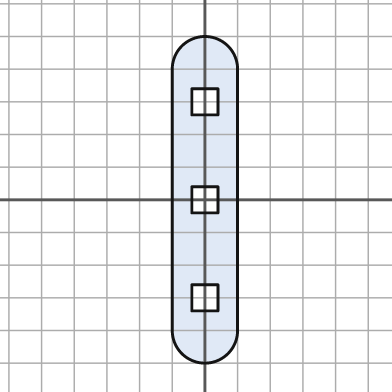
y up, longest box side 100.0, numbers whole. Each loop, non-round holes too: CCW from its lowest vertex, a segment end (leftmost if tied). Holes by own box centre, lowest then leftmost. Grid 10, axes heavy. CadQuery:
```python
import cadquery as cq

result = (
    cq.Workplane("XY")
    .moveTo(-10.0, -40.0)
    .threePointArc((0.0, -50.0), (10.0, -40.0))
    .lineTo(10.0, 40.0)
    .threePointArc((0.0, 50.0), (-10.0, 40.0))
    .close()
    .moveTo(-4.0, -34.0)
    .lineTo(4.0, -34.0)
    .lineTo(4.0, -26.0)
    .lineTo(-4.0, -26.0)
    .close()
    .moveTo(-4.0, -4.0)
    .lineTo(4.0, -4.0)
    .lineTo(4.0, 4.0)
    .lineTo(-4.0, 4.0)
    .close()
    .moveTo(-4.0, 26.0)
    .lineTo(4.0, 26.0)
    .lineTo(4.0, 34.0)
    .lineTo(-4.0, 34.0)
    .close()
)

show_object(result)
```